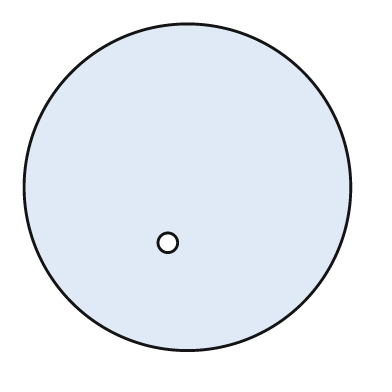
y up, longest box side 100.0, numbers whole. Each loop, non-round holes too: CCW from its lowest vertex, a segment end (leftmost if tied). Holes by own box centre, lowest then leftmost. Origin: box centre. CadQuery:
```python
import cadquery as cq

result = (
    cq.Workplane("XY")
    .moveTo(0.0, 0.0)
    .circle(50.0)
    .moveTo(-6.0, -17.0)
    .circle(3.0)
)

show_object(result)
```